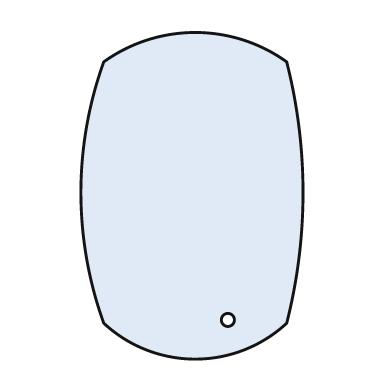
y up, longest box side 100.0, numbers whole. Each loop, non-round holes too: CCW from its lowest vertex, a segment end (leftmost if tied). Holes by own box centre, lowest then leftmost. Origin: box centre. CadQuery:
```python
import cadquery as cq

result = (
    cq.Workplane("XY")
    .moveTo(-27.0, -39.0)
    .threePointArc((1.0, -50.0), (29.0, -39.0))
    .threePointArc((34.0, 1.0), (29.0, 41.0))
    .threePointArc((1.0, 50.0), (-27.0, 41.0))
    .threePointArc((-34.0, 1.0), (-27.0, -39.0))
    .close()
    .moveTo(11.0, -38.0)
    .circle(2.0)
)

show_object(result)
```